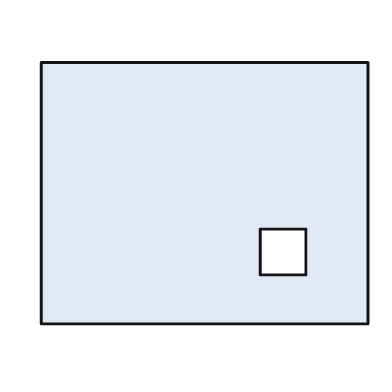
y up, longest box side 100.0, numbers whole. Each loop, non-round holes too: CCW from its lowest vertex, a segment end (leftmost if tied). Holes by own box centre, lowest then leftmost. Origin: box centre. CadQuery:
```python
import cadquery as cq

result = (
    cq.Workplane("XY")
    .moveTo(-50.0, -40.0)
    .lineTo(50.0, -40.0)
    .lineTo(50.0, 40.0)
    .lineTo(-50.0, 40.0)
    .close()
    .moveTo(17.0, -25.0)
    .lineTo(31.0, -25.0)
    .lineTo(31.0, -11.0)
    .lineTo(17.0, -11.0)
    .close()
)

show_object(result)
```